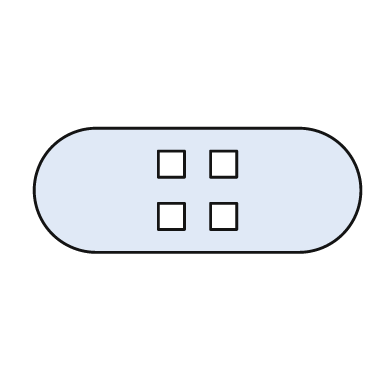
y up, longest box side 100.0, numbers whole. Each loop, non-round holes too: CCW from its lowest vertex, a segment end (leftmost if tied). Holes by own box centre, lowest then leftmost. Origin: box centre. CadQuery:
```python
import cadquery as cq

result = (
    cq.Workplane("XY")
    .moveTo(-31.0, -19.0)
    .lineTo(31.0, -19.0)
    .threePointArc((50.0, 0.0), (31.0, 19.0))
    .lineTo(-31.0, 19.0)
    .threePointArc((-50.0, 0.0), (-31.0, -19.0))
    .close()
    .moveTo(-12.0, -12.0)
    .lineTo(-4.0, -12.0)
    .lineTo(-4.0, -4.0)
    .lineTo(-12.0, -4.0)
    .close()
    .moveTo(4.0, -12.0)
    .lineTo(12.0, -12.0)
    .lineTo(12.0, -4.0)
    .lineTo(4.0, -4.0)
    .close()
    .moveTo(-12.0, 4.0)
    .lineTo(-4.0, 4.0)
    .lineTo(-4.0, 12.0)
    .lineTo(-12.0, 12.0)
    .close()
    .moveTo(4.0, 4.0)
    .lineTo(12.0, 4.0)
    .lineTo(12.0, 12.0)
    .lineTo(4.0, 12.0)
    .close()
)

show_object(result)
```